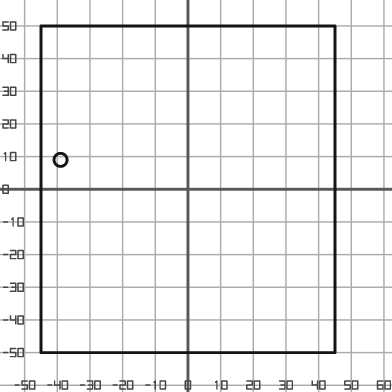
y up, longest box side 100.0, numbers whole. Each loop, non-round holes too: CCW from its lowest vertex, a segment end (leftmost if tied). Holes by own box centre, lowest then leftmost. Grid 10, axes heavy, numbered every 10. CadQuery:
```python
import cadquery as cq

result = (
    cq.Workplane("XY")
    .moveTo(-45.0, -50.0)
    .lineTo(45.0, -50.0)
    .lineTo(45.0, 50.0)
    .lineTo(-45.0, 50.0)
    .close()
    .moveTo(-39.0, 9.0)
    .circle(2.0)
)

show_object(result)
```